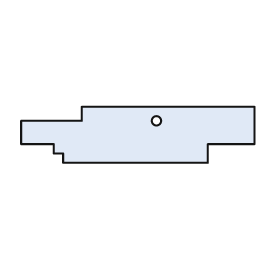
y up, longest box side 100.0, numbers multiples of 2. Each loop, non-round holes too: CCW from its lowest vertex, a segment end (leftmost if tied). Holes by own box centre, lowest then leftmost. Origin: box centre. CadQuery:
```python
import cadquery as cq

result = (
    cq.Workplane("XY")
    .moveTo(-32.0, -12.0)
    .lineTo(30.0, -12.0)
    .lineTo(30.0, -4.0)
    .lineTo(50.0, -4.0)
    .lineTo(50.0, 12.0)
    .lineTo(-24.0, 12.0)
    .lineTo(-24.0, 6.0)
    .lineTo(-50.0, 6.0)
    .lineTo(-50.0, -4.0)
    .lineTo(-36.0, -4.0)
    .lineTo(-36.0, -8.0)
    .lineTo(-32.0, -8.0)
    .close()
    .moveTo(8.0, 6.0)
    .circle(2.0)
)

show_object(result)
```